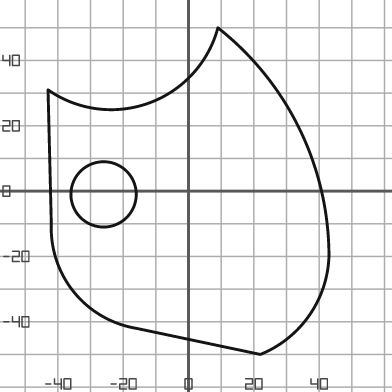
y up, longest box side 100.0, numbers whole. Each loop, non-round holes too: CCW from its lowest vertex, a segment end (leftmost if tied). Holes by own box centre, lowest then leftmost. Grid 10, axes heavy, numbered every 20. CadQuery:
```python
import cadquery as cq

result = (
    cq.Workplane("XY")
    .moveTo(22.0, -50.0)
    .threePointArc((37.0, -38.0), (43.0, -20.0))
    .threePointArc((34.0, 19.0), (9.0, 50.0))
    .threePointArc((-12.0, 27.0), (-43.0, 31.0))
    .lineTo(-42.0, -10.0)
    .threePointArc((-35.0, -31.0), (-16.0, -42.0))
    .close()
    .moveTo(-26.0, -1.0)
    .circle(10.0)
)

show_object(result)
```